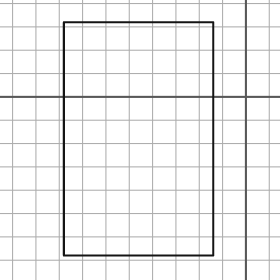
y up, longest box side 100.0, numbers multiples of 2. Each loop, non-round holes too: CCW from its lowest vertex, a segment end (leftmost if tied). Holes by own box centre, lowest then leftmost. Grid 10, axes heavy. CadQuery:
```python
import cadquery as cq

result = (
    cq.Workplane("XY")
    .moveTo(-78.0, -68.0)
    .lineTo(-14.0, -68.0)
    .lineTo(-14.0, 32.0)
    .lineTo(-78.0, 32.0)
    .close()
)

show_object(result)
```